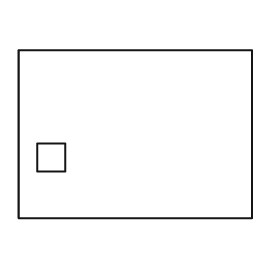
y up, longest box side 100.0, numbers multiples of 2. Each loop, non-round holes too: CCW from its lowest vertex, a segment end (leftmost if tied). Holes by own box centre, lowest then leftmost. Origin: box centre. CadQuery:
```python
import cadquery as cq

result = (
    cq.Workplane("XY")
    .moveTo(-50.0, -36.0)
    .lineTo(50.0, -36.0)
    .lineTo(50.0, 36.0)
    .lineTo(-50.0, 36.0)
    .close()
    .moveTo(-42.0, -16.0)
    .lineTo(-30.0, -16.0)
    .lineTo(-30.0, -4.0)
    .lineTo(-42.0, -4.0)
    .close()
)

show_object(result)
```